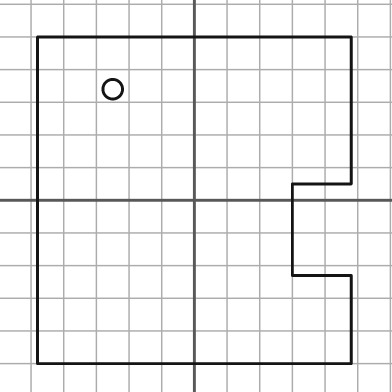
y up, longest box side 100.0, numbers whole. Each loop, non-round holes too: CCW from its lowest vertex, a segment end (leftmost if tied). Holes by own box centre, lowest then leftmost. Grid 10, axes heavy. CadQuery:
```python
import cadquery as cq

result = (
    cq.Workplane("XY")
    .moveTo(-48.0, -50.0)
    .lineTo(48.0, -50.0)
    .lineTo(48.0, -23.0)
    .lineTo(30.0, -23.0)
    .lineTo(30.0, 5.0)
    .lineTo(48.0, 5.0)
    .lineTo(48.0, 50.0)
    .lineTo(-48.0, 50.0)
    .close()
    .moveTo(-25.0, 34.0)
    .circle(3.0)
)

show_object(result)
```